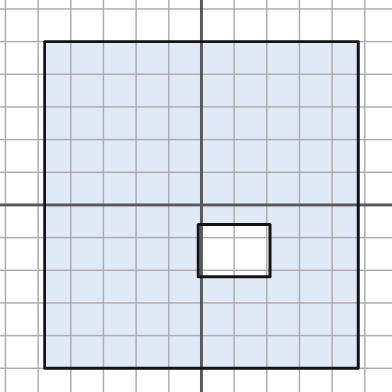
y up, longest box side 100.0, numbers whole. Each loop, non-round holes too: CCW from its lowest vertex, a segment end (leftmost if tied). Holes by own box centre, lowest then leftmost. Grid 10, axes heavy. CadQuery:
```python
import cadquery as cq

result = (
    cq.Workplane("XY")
    .moveTo(-48.0, -50.0)
    .lineTo(48.0, -50.0)
    .lineTo(48.0, 50.0)
    .lineTo(-48.0, 50.0)
    .close()
    .moveTo(-1.0, -22.0)
    .lineTo(21.0, -22.0)
    .lineTo(21.0, -6.0)
    .lineTo(-1.0, -6.0)
    .close()
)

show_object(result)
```